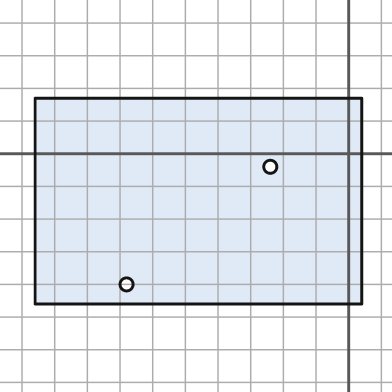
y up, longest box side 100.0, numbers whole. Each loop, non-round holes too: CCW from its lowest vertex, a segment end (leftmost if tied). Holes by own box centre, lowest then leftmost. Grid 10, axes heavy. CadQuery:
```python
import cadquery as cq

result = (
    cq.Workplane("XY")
    .moveTo(-96.0, -46.0)
    .lineTo(4.0, -46.0)
    .lineTo(4.0, 17.0)
    .lineTo(-96.0, 17.0)
    .close()
    .moveTo(-68.0, -40.0)
    .circle(2.0)
    .moveTo(-24.0, -4.0)
    .circle(2.0)
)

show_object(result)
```